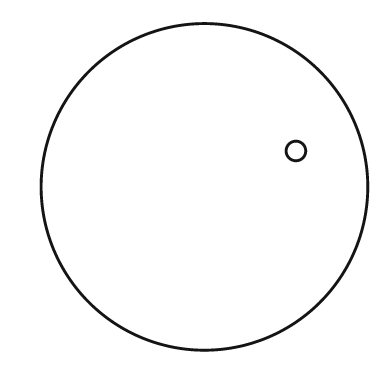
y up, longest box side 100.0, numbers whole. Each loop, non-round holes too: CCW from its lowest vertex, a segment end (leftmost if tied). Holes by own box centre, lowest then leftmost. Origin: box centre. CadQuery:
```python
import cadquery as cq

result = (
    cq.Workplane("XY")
    .moveTo(0.0, 0.0)
    .circle(50.0)
    .moveTo(28.0, 11.0)
    .circle(3.0)
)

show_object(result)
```